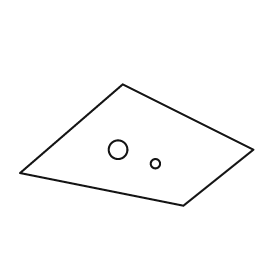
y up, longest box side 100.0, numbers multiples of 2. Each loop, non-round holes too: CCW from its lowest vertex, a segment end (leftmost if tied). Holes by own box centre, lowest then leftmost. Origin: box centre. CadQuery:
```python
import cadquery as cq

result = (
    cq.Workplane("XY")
    .moveTo(20.0, -26.0)
    .lineTo(50.0, -2.0)
    .lineTo(-6.0, 26.0)
    .lineTo(-50.0, -12.0)
    .close()
    .moveTo(8.0, -8.0)
    .circle(2.0)
    .moveTo(-8.0, -2.0)
    .circle(4.0)
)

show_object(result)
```